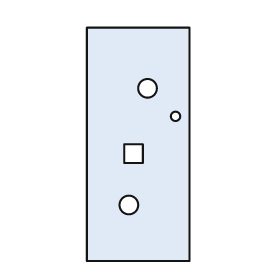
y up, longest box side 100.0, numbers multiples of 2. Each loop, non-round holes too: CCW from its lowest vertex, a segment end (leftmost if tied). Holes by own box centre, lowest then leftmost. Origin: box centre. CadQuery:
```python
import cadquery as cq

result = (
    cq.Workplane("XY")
    .moveTo(-22.0, -50.0)
    .lineTo(22.0, -50.0)
    .lineTo(22.0, 50.0)
    .lineTo(-22.0, 50.0)
    .close()
    .moveTo(-4.0, -26.0)
    .circle(4.0)
    .moveTo(-6.0, -8.0)
    .lineTo(2.0, -8.0)
    .lineTo(2.0, 0.0)
    .lineTo(-6.0, 0.0)
    .close()
    .moveTo(16.0, 12.0)
    .circle(2.0)
    .moveTo(4.0, 24.0)
    .circle(4.0)
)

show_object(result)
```